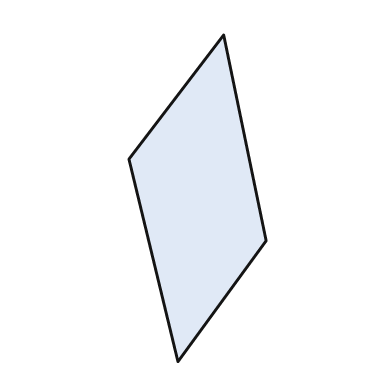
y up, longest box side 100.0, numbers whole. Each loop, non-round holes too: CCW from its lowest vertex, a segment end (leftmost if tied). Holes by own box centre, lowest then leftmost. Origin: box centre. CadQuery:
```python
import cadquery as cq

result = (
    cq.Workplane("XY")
    .moveTo(-6.0, -50.0)
    .lineTo(21.0, -13.0)
    .lineTo(8.0, 50.0)
    .lineTo(-21.0, 12.0)
    .close()
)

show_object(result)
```